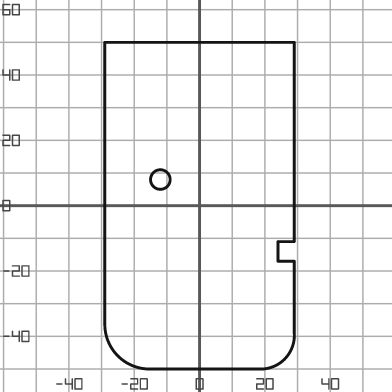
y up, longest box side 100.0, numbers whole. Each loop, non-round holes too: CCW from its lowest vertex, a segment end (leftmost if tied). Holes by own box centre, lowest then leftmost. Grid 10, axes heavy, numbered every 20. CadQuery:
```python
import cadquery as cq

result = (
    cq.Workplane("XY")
    .moveTo(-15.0, -50.0)
    .lineTo(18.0, -50.0)
    .threePointArc((26.0, -47.0), (29.0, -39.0))
    .lineTo(29.0, -17.0)
    .lineTo(24.0, -17.0)
    .lineTo(24.0, -11.0)
    .lineTo(29.0, -11.0)
    .lineTo(29.0, 50.0)
    .lineTo(-29.0, 50.0)
    .lineTo(-29.0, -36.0)
    .threePointArc((-25.0, -46.0), (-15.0, -50.0))
    .close()
    .moveTo(-12.0, 8.0)
    .circle(3.0)
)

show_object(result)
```